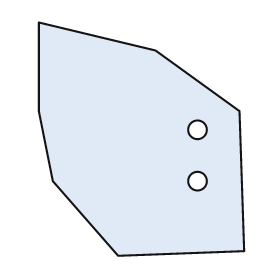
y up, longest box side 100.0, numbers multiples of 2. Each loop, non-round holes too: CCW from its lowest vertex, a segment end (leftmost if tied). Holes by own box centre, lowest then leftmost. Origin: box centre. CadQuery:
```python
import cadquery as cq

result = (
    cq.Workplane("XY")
    .moveTo(-10.0, -50.0)
    .lineTo(44.0, -48.0)
    .lineTo(42.0, 12.0)
    .lineTo(6.0, 38.0)
    .lineTo(-44.0, 50.0)
    .lineTo(-44.0, 12.0)
    .lineTo(-38.0, -18.0)
    .close()
    .moveTo(24.0, -18.0)
    .circle(4.0)
    .moveTo(24.0, 4.0)
    .circle(4.0)
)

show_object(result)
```